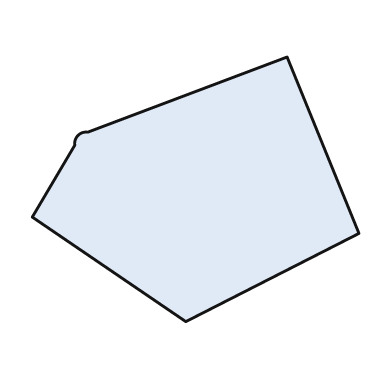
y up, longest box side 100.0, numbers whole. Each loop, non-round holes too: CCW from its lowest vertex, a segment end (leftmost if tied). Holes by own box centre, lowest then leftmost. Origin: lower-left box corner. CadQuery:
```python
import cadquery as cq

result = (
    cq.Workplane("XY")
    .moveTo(47.0, 0.0)
    .lineTo(100.0, 27.0)
    .lineTo(78.0, 81.0)
    .lineTo(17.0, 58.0)
    .threePointArc((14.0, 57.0), (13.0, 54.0))
    .lineTo(0.0, 32.0)
    .close()
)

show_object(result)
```